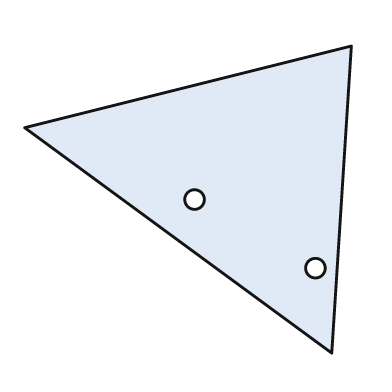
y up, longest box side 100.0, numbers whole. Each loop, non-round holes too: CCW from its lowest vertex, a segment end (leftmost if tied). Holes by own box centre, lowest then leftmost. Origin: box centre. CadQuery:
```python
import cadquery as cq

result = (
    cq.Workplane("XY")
    .moveTo(44.0, -47.0)
    .lineTo(50.0, 47.0)
    .lineTo(-50.0, 22.0)
    .close()
    .moveTo(39.0, -21.0)
    .circle(3.0)
    .moveTo(2.0, 0.0)
    .circle(3.0)
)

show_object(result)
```